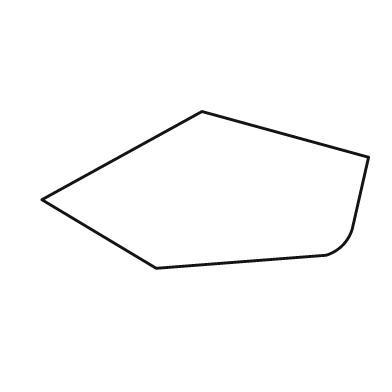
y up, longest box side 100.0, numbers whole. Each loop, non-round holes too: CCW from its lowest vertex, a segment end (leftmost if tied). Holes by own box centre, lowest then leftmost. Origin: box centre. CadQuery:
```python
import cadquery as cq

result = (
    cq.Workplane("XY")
    .moveTo(-15.0, -24.0)
    .lineTo(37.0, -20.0)
    .threePointArc((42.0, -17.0), (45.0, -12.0))
    .lineTo(50.0, 10.0)
    .lineTo(-1.0, 24.0)
    .lineTo(-50.0, -3.0)
    .close()
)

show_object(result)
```